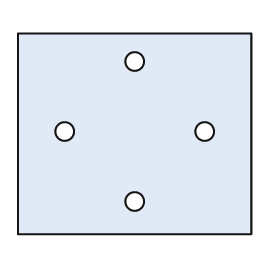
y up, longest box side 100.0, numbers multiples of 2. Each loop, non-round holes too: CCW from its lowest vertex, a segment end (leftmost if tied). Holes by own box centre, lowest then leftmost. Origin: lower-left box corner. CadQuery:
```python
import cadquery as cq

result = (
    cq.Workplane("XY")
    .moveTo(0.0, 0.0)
    .lineTo(100.0, 0.0)
    .lineTo(100.0, 86.0)
    .lineTo(0.0, 86.0)
    .close()
    .moveTo(50.0, 14.0)
    .circle(4.0)
    .moveTo(20.0, 44.0)
    .circle(4.0)
    .moveTo(80.0, 44.0)
    .circle(4.0)
    .moveTo(50.0, 74.0)
    .circle(4.0)
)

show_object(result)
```